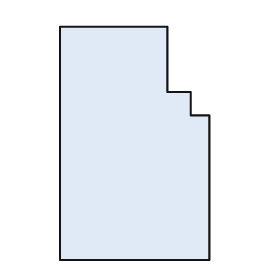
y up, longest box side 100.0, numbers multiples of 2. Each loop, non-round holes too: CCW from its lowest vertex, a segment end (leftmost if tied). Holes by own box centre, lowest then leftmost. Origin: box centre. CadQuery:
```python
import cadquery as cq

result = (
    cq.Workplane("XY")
    .moveTo(-32.0, -50.0)
    .lineTo(32.0, -50.0)
    .lineTo(32.0, 12.0)
    .lineTo(24.0, 12.0)
    .lineTo(24.0, 22.0)
    .lineTo(14.0, 22.0)
    .lineTo(14.0, 50.0)
    .lineTo(-32.0, 50.0)
    .close()
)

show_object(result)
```